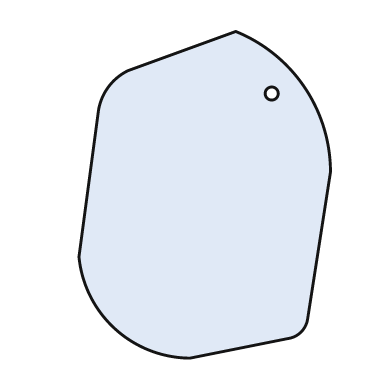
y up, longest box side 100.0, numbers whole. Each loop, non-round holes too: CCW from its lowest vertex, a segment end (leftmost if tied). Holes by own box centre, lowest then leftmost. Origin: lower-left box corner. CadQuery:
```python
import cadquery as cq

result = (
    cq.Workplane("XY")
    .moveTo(34.0, 0.0)
    .lineTo(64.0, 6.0)
    .threePointArc((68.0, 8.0), (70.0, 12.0))
    .lineTo(77.0, 57.0)
    .threePointArc((69.0, 83.0), (48.0, 100.0))
    .lineTo(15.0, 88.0)
    .threePointArc((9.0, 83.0), (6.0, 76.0))
    .lineTo(0.0, 31.0)
    .threePointArc((11.0, 9.0), (34.0, 0.0))
    .close()
    .moveTo(59.0, 81.0)
    .circle(2.0)
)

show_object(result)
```